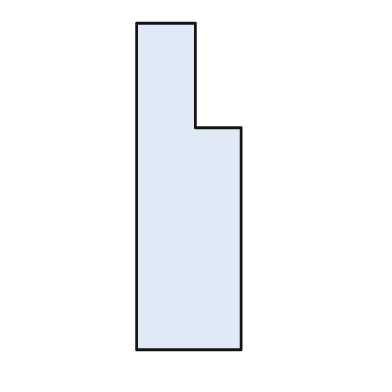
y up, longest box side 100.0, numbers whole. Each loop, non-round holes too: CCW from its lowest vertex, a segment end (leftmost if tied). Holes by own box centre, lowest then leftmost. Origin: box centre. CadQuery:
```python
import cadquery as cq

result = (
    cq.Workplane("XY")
    .moveTo(-16.0, -50.0)
    .lineTo(16.0, -50.0)
    .lineTo(16.0, 18.0)
    .lineTo(2.0, 18.0)
    .lineTo(2.0, 50.0)
    .lineTo(-16.0, 50.0)
    .close()
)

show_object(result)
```